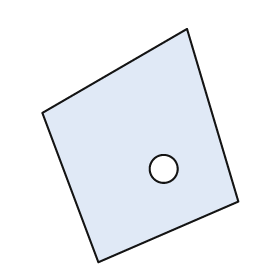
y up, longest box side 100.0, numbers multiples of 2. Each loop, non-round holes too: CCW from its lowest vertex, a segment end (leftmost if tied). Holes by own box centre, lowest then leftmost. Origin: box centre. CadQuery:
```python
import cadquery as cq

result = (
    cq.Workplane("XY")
    .moveTo(-18.0, -50.0)
    .lineTo(42.0, -24.0)
    .lineTo(20.0, 50.0)
    .lineTo(-42.0, 14.0)
    .close()
    .moveTo(10.0, -10.0)
    .circle(6.0)
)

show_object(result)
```